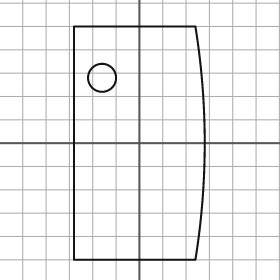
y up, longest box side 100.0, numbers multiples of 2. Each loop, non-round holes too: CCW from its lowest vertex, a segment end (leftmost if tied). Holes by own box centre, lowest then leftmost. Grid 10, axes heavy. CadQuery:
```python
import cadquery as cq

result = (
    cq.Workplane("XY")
    .moveTo(-28.0, -50.0)
    .lineTo(24.0, -50.0)
    .threePointArc((28.0, 0.0), (24.0, 50.0))
    .lineTo(-28.0, 50.0)
    .close()
    .moveTo(-16.0, 28.0)
    .circle(6.0)
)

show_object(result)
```